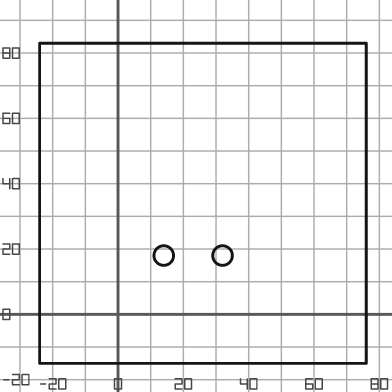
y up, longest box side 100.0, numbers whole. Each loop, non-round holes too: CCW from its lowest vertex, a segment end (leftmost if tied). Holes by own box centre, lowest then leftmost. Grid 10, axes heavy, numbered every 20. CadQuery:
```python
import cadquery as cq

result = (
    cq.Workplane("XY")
    .moveTo(-24.0, -15.0)
    .lineTo(76.0, -15.0)
    .lineTo(76.0, 83.0)
    .lineTo(-24.0, 83.0)
    .close()
    .moveTo(14.0, 18.0)
    .circle(3.0)
    .moveTo(32.0, 18.0)
    .circle(3.0)
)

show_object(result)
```